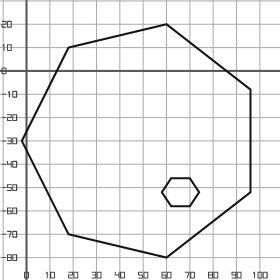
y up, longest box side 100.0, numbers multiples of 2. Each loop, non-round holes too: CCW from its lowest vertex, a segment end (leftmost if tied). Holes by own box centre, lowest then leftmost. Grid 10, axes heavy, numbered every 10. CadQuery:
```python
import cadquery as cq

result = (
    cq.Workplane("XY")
    .moveTo(60.0, -80.0)
    .lineTo(96.0, -52.0)
    .lineTo(96.0, -8.0)
    .lineTo(60.0, 20.0)
    .lineTo(18.0, 10.0)
    .lineTo(-2.0, -30.0)
    .lineTo(18.0, -70.0)
    .close()
    .moveTo(62.0, -58.0)
    .lineTo(70.0, -58.0)
    .lineTo(74.0, -52.0)
    .lineTo(70.0, -46.0)
    .lineTo(62.0, -46.0)
    .lineTo(58.0, -52.0)
    .close()
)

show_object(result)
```